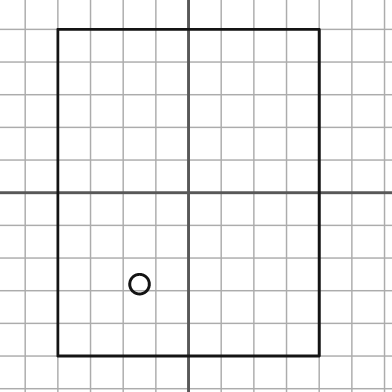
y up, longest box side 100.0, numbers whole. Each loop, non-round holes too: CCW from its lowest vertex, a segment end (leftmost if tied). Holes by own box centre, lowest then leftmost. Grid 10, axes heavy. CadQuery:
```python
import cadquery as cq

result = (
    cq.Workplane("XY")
    .moveTo(-40.0, -50.0)
    .lineTo(40.0, -50.0)
    .lineTo(40.0, 50.0)
    .lineTo(-40.0, 50.0)
    .close()
    .moveTo(-15.0, -28.0)
    .circle(3.0)
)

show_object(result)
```